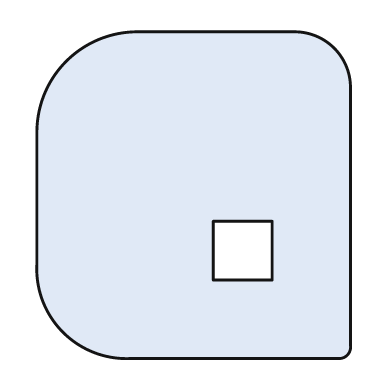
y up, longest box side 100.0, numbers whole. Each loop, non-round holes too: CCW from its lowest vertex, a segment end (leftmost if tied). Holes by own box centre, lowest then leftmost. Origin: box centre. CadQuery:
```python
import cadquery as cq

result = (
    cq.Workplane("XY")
    .moveTo(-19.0, -50.0)
    .lineTo(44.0, -50.0)
    .threePointArc((47.0, -49.0), (48.0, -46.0))
    .lineTo(48.0, 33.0)
    .threePointArc((43.0, 45.0), (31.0, 50.0))
    .lineTo(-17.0, 50.0)
    .threePointArc((-39.0, 41.0), (-48.0, 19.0))
    .lineTo(-48.0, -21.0)
    .threePointArc((-40.0, -42.0), (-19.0, -50.0))
    .close()
    .moveTo(6.0, -26.0)
    .lineTo(24.0, -26.0)
    .lineTo(24.0, -8.0)
    .lineTo(6.0, -8.0)
    .close()
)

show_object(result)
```